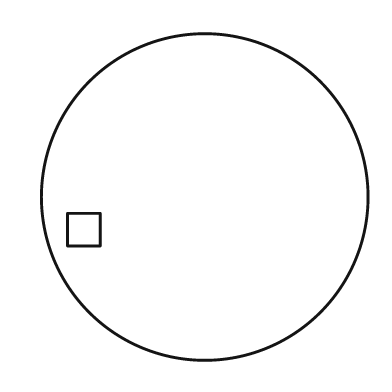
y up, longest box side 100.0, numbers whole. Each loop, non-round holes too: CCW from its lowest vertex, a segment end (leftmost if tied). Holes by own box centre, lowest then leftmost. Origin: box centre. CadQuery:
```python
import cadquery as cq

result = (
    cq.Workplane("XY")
    .moveTo(0.0, 0.0)
    .circle(50.0)
    .moveTo(-42.0, -15.0)
    .lineTo(-32.0, -15.0)
    .lineTo(-32.0, -5.0)
    .lineTo(-42.0, -5.0)
    .close()
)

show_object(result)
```